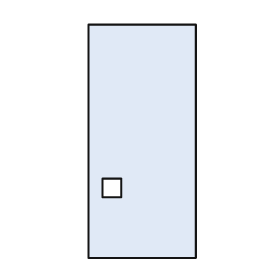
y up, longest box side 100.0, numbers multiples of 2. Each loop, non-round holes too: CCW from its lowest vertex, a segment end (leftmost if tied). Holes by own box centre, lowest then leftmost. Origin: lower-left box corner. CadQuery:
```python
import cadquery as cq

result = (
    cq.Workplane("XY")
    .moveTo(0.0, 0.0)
    .lineTo(46.0, 0.0)
    .lineTo(46.0, 100.0)
    .lineTo(0.0, 100.0)
    .close()
    .moveTo(6.0, 26.0)
    .lineTo(14.0, 26.0)
    .lineTo(14.0, 34.0)
    .lineTo(6.0, 34.0)
    .close()
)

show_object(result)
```